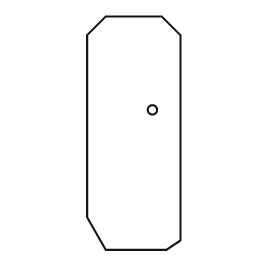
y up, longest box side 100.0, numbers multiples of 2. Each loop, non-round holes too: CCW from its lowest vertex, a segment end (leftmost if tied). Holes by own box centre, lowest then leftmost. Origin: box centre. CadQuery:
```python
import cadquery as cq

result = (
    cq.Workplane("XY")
    .moveTo(-12.0, -50.0)
    .lineTo(14.0, -50.0)
    .lineTo(20.0, -46.0)
    .lineTo(20.0, 42.0)
    .lineTo(12.0, 50.0)
    .lineTo(-12.0, 50.0)
    .lineTo(-20.0, 42.0)
    .lineTo(-20.0, -36.0)
    .close()
    .moveTo(8.0, 10.0)
    .circle(2.0)
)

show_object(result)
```